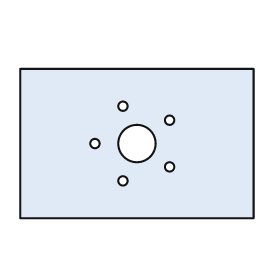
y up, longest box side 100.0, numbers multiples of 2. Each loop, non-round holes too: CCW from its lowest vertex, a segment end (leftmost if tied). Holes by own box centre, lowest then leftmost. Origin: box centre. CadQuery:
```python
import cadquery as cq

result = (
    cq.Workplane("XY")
    .moveTo(-50.0, -32.0)
    .lineTo(50.0, -32.0)
    .lineTo(50.0, 32.0)
    .lineTo(-50.0, 32.0)
    .close()
    .moveTo(-6.0, -16.0)
    .circle(2.0)
    .moveTo(14.0, -10.0)
    .circle(2.0)
    .moveTo(-18.0, 0.0)
    .circle(2.0)
    .moveTo(0.0, 0.0)
    .circle(8.0)
    .moveTo(14.0, 10.0)
    .circle(2.0)
    .moveTo(-6.0, 16.0)
    .circle(2.0)
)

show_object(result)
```